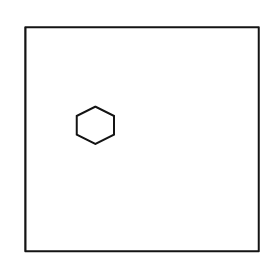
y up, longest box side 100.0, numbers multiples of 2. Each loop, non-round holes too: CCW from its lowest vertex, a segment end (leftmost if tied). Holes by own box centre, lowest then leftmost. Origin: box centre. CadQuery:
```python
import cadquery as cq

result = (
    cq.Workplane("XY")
    .moveTo(-50.0, -48.0)
    .lineTo(50.0, -48.0)
    .lineTo(50.0, 48.0)
    .lineTo(-50.0, 48.0)
    .close()
    .moveTo(-20.0, -2.0)
    .lineTo(-12.0, 2.0)
    .lineTo(-12.0, 10.0)
    .lineTo(-20.0, 14.0)
    .lineTo(-28.0, 10.0)
    .lineTo(-28.0, 2.0)
    .close()
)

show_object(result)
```